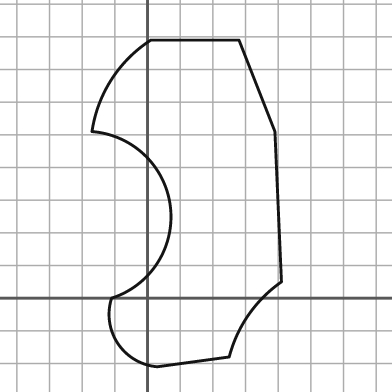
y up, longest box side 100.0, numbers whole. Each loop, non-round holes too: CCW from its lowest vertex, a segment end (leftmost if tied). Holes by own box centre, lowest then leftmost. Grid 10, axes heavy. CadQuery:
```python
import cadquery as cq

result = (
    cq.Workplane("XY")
    .moveTo(3.0, -21.0)
    .lineTo(25.0, -18.0)
    .threePointArc((31.0, -5.0), (41.0, 5.0))
    .lineTo(39.0, 51.0)
    .lineTo(28.0, 79.0)
    .lineTo(1.0, 79.0)
    .threePointArc((-11.0, 67.0), (-17.0, 51.0))
    .threePointArc((7.0, 28.0), (-11.0, 0.0))
    .threePointArc((-9.0, -14.0), (3.0, -21.0))
    .close()
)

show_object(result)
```